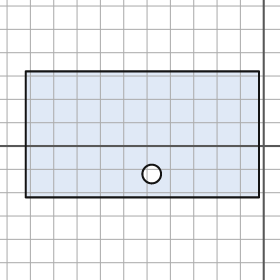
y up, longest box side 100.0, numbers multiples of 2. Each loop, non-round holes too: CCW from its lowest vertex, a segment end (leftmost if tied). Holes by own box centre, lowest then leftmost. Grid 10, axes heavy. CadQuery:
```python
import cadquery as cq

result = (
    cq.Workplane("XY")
    .moveTo(-102.0, -22.0)
    .lineTo(-2.0, -22.0)
    .lineTo(-2.0, 32.0)
    .lineTo(-102.0, 32.0)
    .close()
    .moveTo(-48.0, -12.0)
    .circle(4.0)
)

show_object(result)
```